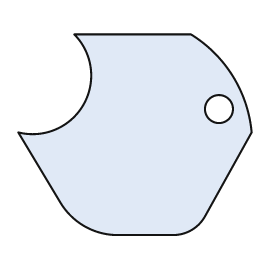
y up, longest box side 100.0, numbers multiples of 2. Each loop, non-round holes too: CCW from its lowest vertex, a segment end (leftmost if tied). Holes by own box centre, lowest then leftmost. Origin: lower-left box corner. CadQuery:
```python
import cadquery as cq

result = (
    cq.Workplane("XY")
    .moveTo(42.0, 0.0)
    .lineTo(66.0, 0.0)
    .threePointArc((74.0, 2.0), (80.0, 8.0))
    .lineTo(100.0, 44.0)
    .threePointArc((92.0, 68.0), (74.0, 86.0))
    .lineTo(24.0, 86.0)
    .threePointArc((28.0, 56.0), (0.0, 44.0))
    .lineTo(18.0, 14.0)
    .threePointArc((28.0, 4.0), (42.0, 0.0))
    .close()
    .moveTo(86.0, 54.0)
    .circle(6.0)
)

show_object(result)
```